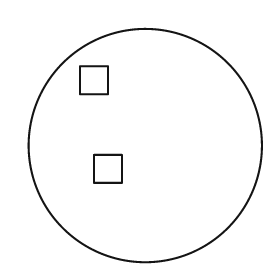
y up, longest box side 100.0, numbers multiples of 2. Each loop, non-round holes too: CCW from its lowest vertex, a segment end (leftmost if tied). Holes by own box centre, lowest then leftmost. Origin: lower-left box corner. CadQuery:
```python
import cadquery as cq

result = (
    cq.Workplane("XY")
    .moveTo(50.0, 50.0)
    .circle(50.0)
    .moveTo(28.0, 34.0)
    .lineTo(40.0, 34.0)
    .lineTo(40.0, 46.0)
    .lineTo(28.0, 46.0)
    .close()
    .moveTo(22.0, 72.0)
    .lineTo(34.0, 72.0)
    .lineTo(34.0, 84.0)
    .lineTo(22.0, 84.0)
    .close()
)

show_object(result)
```